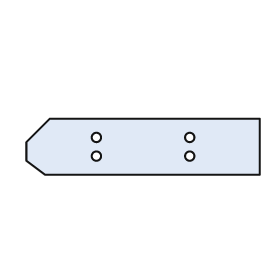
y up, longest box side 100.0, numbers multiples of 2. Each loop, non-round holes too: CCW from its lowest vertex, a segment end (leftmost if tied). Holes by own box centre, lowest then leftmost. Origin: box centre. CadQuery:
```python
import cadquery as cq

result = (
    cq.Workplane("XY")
    .moveTo(-42.0, -12.0)
    .lineTo(50.0, -12.0)
    .lineTo(50.0, 12.0)
    .lineTo(-40.0, 12.0)
    .lineTo(-50.0, 2.0)
    .lineTo(-50.0, -6.0)
    .close()
    .moveTo(-20.0, -4.0)
    .circle(2.0)
    .moveTo(20.0, -4.0)
    .circle(2.0)
    .moveTo(-20.0, 4.0)
    .circle(2.0)
    .moveTo(20.0, 4.0)
    .circle(2.0)
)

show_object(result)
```